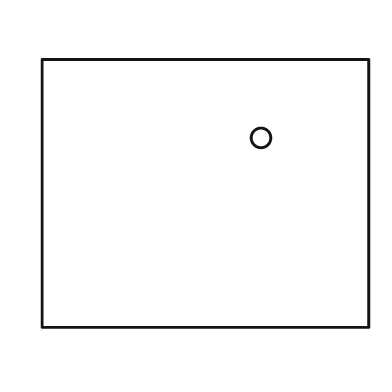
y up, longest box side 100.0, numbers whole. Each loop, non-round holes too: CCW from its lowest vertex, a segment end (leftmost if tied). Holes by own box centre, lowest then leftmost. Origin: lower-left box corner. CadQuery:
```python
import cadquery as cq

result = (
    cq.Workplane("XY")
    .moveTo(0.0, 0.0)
    .lineTo(100.0, 0.0)
    .lineTo(100.0, 82.0)
    .lineTo(0.0, 82.0)
    .close()
    .moveTo(67.0, 58.0)
    .circle(3.0)
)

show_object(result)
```